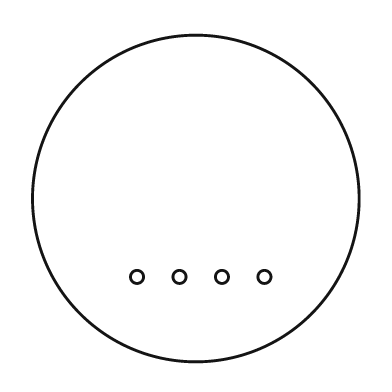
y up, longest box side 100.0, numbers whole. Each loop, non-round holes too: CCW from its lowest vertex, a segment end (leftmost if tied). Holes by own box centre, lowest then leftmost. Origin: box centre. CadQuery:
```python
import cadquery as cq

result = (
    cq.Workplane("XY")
    .moveTo(0.0, 0.0)
    .circle(50.0)
    .moveTo(-18.0, -24.0)
    .circle(2.0)
    .moveTo(-5.0, -24.0)
    .circle(2.0)
    .moveTo(8.0, -24.0)
    .circle(2.0)
    .moveTo(21.0, -24.0)
    .circle(2.0)
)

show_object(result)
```